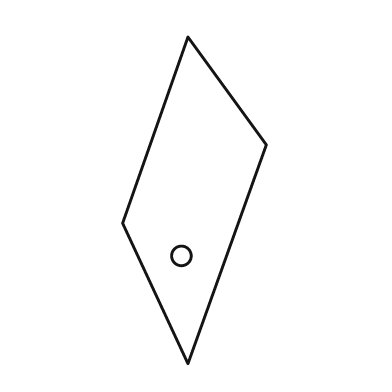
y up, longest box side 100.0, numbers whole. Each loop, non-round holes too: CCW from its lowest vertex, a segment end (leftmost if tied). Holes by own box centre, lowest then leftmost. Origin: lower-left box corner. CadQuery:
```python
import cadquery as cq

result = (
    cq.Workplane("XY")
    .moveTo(20.0, 0.0)
    .lineTo(44.0, 67.0)
    .lineTo(20.0, 100.0)
    .lineTo(0.0, 43.0)
    .close()
    .moveTo(18.0, 33.0)
    .circle(3.0)
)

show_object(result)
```